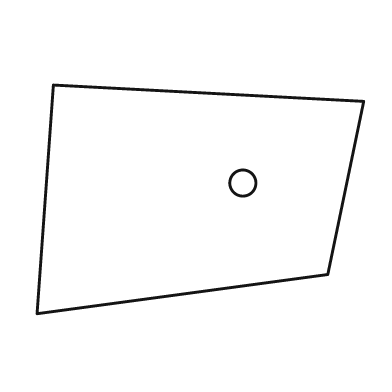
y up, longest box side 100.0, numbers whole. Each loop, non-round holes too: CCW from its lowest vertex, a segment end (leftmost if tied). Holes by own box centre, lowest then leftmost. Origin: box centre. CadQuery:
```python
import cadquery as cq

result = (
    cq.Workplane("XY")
    .moveTo(-50.0, -35.0)
    .lineTo(39.0, -23.0)
    .lineTo(50.0, 30.0)
    .lineTo(-45.0, 35.0)
    .close()
    .moveTo(13.0, 5.0)
    .circle(4.0)
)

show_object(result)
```